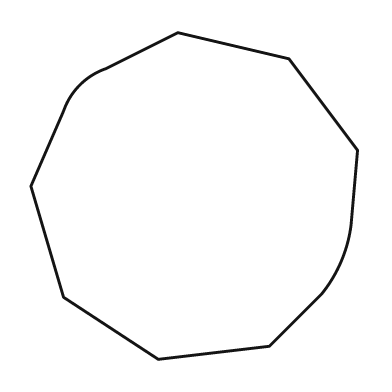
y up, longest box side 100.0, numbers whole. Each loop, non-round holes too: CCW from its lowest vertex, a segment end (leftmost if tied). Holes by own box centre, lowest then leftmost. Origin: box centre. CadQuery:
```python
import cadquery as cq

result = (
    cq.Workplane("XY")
    .moveTo(-11.0, -50.0)
    .lineTo(23.0, -46.0)
    .lineTo(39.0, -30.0)
    .threePointArc((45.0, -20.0), (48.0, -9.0))
    .lineTo(50.0, 14.0)
    .lineTo(29.0, 42.0)
    .lineTo(-5.0, 50.0)
    .lineTo(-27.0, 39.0)
    .threePointArc((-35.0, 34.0), (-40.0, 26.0))
    .lineTo(-50.0, 3.0)
    .lineTo(-40.0, -31.0)
    .close()
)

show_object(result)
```